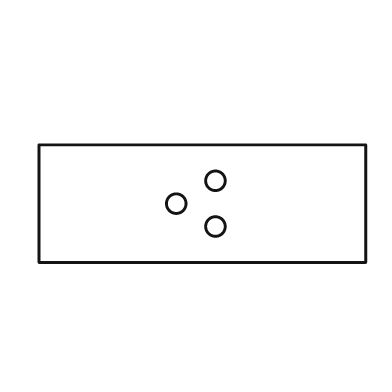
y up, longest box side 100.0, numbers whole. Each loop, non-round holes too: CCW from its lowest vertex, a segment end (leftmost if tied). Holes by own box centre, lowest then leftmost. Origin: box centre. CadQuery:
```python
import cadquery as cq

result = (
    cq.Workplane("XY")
    .moveTo(-50.0, -18.0)
    .lineTo(50.0, -18.0)
    .lineTo(50.0, 18.0)
    .lineTo(-50.0, 18.0)
    .close()
    .moveTo(4.0, -7.0)
    .circle(3.0)
    .moveTo(-8.0, 0.0)
    .circle(3.0)
    .moveTo(4.0, 7.0)
    .circle(3.0)
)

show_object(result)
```